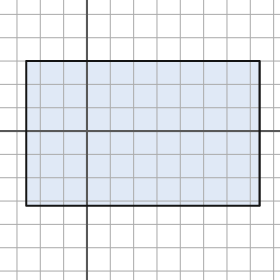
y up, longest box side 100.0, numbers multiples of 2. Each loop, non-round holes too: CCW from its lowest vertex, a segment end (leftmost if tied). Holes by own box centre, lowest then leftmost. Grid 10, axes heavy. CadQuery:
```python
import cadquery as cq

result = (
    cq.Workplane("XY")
    .moveTo(-26.0, -32.0)
    .lineTo(74.0, -32.0)
    .lineTo(74.0, 30.0)
    .lineTo(-26.0, 30.0)
    .close()
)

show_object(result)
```